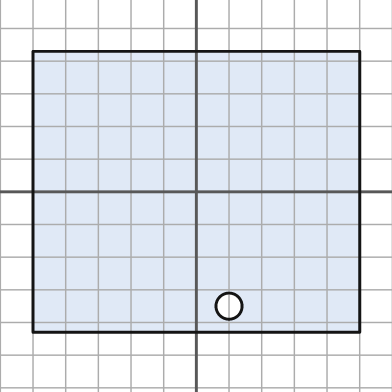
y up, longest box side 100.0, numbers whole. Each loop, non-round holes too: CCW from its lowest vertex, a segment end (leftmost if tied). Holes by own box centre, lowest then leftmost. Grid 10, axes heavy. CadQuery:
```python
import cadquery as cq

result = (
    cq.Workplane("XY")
    .moveTo(-50.0, -43.0)
    .lineTo(50.0, -43.0)
    .lineTo(50.0, 43.0)
    .lineTo(-50.0, 43.0)
    .close()
    .moveTo(10.0, -35.0)
    .circle(4.0)
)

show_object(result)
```